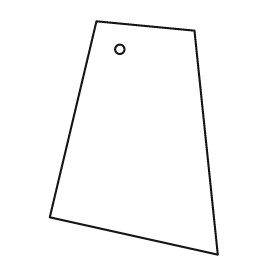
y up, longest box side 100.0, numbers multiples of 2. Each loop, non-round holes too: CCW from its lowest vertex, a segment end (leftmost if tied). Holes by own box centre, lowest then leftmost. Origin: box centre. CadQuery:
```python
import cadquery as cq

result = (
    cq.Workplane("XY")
    .moveTo(36.0, -50.0)
    .lineTo(26.0, 46.0)
    .lineTo(-16.0, 50.0)
    .lineTo(-36.0, -34.0)
    .close()
    .moveTo(-6.0, 38.0)
    .circle(2.0)
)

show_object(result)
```